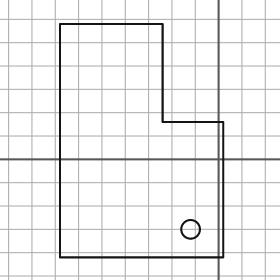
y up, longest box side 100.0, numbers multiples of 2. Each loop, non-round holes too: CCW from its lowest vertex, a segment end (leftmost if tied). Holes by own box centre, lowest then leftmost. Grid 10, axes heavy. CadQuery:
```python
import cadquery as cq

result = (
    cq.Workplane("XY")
    .moveTo(-68.0, -42.0)
    .lineTo(2.0, -42.0)
    .lineTo(2.0, 16.0)
    .lineTo(-24.0, 16.0)
    .lineTo(-24.0, 58.0)
    .lineTo(-68.0, 58.0)
    .close()
    .moveTo(-12.0, -30.0)
    .circle(4.0)
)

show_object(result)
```